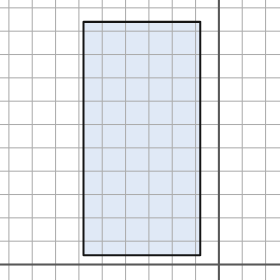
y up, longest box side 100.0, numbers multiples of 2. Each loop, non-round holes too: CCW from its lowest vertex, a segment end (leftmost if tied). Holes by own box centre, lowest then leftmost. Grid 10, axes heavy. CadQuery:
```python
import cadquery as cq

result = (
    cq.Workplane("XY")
    .moveTo(-58.0, 4.0)
    .lineTo(-8.0, 4.0)
    .lineTo(-8.0, 104.0)
    .lineTo(-58.0, 104.0)
    .close()
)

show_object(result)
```